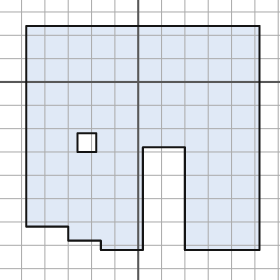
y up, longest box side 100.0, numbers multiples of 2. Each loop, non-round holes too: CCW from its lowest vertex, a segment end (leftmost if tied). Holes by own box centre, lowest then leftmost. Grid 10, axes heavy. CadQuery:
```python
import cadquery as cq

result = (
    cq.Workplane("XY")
    .moveTo(-16.0, -72.0)
    .lineTo(2.0, -72.0)
    .lineTo(2.0, -28.0)
    .lineTo(20.0, -28.0)
    .lineTo(20.0, -72.0)
    .lineTo(52.0, -72.0)
    .lineTo(52.0, 24.0)
    .lineTo(-48.0, 24.0)
    .lineTo(-48.0, -62.0)
    .lineTo(-30.0, -62.0)
    .lineTo(-30.0, -68.0)
    .lineTo(-16.0, -68.0)
    .close()
    .moveTo(-26.0, -30.0)
    .lineTo(-18.0, -30.0)
    .lineTo(-18.0, -22.0)
    .lineTo(-26.0, -22.0)
    .close()
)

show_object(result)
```